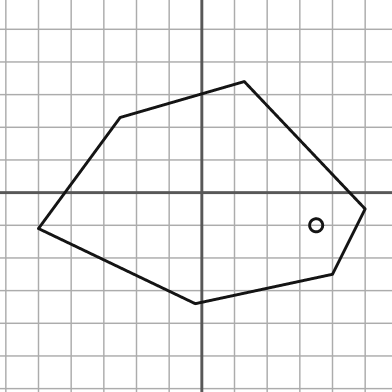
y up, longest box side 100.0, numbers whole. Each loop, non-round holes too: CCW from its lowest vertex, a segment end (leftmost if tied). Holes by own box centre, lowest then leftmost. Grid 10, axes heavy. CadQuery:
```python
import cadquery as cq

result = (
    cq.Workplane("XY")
    .moveTo(-2.0, -34.0)
    .lineTo(40.0, -25.0)
    .lineTo(50.0, -5.0)
    .lineTo(13.0, 34.0)
    .lineTo(-25.0, 23.0)
    .lineTo(-50.0, -11.0)
    .close()
    .moveTo(35.0, -10.0)
    .circle(2.0)
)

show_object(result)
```